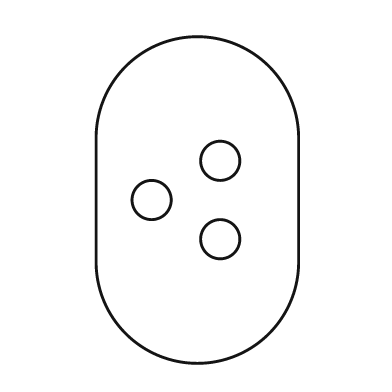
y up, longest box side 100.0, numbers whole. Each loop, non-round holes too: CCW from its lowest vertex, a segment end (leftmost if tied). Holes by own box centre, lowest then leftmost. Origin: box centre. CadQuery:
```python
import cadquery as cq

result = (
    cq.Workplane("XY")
    .moveTo(-31.0, -19.0)
    .threePointArc((0.0, -50.0), (31.0, -19.0))
    .lineTo(31.0, 19.0)
    .threePointArc((0.0, 50.0), (-31.0, 19.0))
    .close()
    .moveTo(7.0, -12.0)
    .circle(6.0)
    .moveTo(-14.0, 0.0)
    .circle(6.0)
    .moveTo(7.0, 12.0)
    .circle(6.0)
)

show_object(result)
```